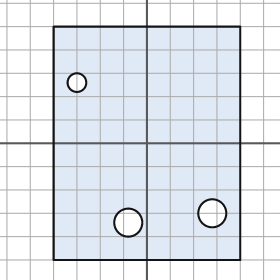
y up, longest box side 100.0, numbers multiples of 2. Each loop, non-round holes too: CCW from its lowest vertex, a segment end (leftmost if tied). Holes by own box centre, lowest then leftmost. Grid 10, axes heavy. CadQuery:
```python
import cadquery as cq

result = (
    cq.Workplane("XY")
    .moveTo(-40.0, -50.0)
    .lineTo(40.0, -50.0)
    .lineTo(40.0, 50.0)
    .lineTo(-40.0, 50.0)
    .close()
    .moveTo(-8.0, -34.0)
    .circle(6.0)
    .moveTo(28.0, -30.0)
    .circle(6.0)
    .moveTo(-30.0, 26.0)
    .circle(4.0)
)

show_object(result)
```